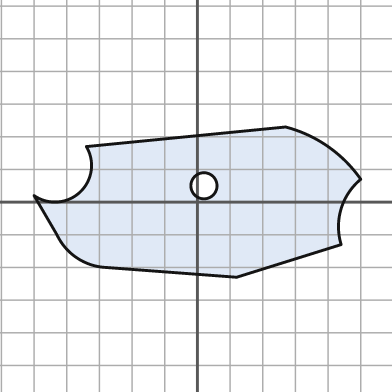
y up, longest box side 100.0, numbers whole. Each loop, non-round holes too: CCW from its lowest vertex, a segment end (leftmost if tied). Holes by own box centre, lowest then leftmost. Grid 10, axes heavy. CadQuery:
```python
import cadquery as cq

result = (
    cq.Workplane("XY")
    .moveTo(12.0, -23.0)
    .lineTo(44.0, -13.0)
    .threePointArc((44.0, -2.0), (50.0, 7.0))
    .threePointArc((40.0, 17.0), (27.0, 23.0))
    .lineTo(-34.0, 17.0)
    .threePointArc((-36.0, 3.0), (-50.0, 2.0))
    .lineTo(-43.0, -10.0)
    .threePointArc((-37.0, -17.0), (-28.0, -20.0))
    .close()
    .moveTo(2.0, 5.0)
    .circle(4.0)
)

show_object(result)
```